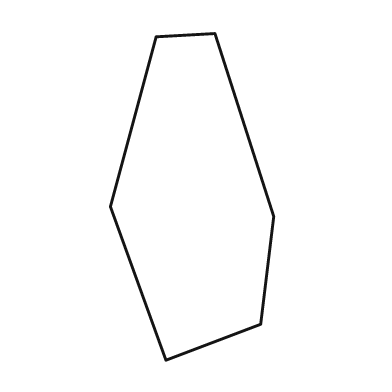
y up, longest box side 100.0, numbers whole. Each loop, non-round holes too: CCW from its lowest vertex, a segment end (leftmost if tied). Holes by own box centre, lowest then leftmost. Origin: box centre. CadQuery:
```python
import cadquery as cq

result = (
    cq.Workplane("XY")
    .moveTo(-8.0, -50.0)
    .lineTo(21.0, -39.0)
    .lineTo(25.0, -6.0)
    .lineTo(7.0, 50.0)
    .lineTo(-11.0, 49.0)
    .lineTo(-25.0, -3.0)
    .close()
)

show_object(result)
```